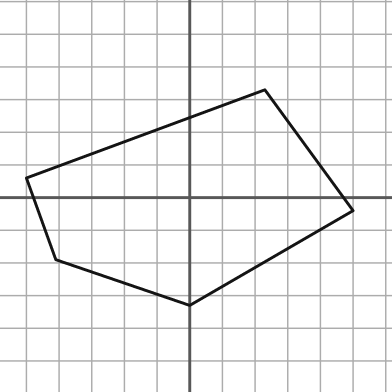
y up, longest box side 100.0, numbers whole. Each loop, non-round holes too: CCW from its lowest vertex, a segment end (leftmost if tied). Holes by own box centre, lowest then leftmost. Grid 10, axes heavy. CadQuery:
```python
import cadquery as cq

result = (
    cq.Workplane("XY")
    .moveTo(0.0, -33.0)
    .lineTo(50.0, -4.0)
    .lineTo(23.0, 33.0)
    .lineTo(-50.0, 6.0)
    .lineTo(-41.0, -19.0)
    .close()
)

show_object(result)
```